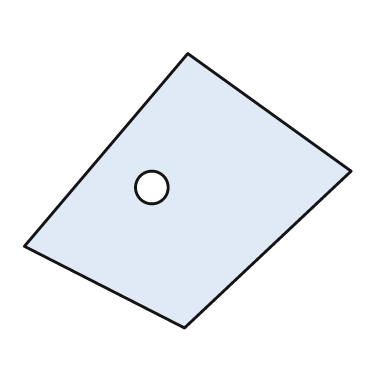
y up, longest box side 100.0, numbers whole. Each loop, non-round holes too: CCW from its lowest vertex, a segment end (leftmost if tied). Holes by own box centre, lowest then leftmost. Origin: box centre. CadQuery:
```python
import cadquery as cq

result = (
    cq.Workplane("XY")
    .moveTo(-1.0, -42.0)
    .lineTo(50.0, 6.0)
    .lineTo(0.0, 42.0)
    .lineTo(-50.0, -17.0)
    .close()
    .moveTo(-11.0, 1.0)
    .circle(5.0)
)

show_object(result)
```